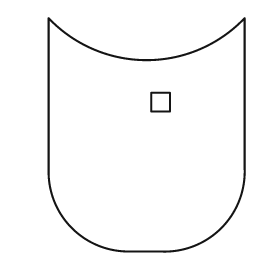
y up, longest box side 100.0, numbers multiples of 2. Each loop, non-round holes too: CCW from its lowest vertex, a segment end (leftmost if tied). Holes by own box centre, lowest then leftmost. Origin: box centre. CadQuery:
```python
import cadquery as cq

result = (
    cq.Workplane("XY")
    .moveTo(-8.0, -50.0)
    .lineTo(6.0, -50.0)
    .threePointArc((32.0, -40.0), (42.0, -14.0))
    .lineTo(42.0, 50.0)
    .threePointArc((0.0, 32.0), (-42.0, 50.0))
    .lineTo(-42.0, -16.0)
    .threePointArc((-32.0, -40.0), (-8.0, -50.0))
    .close()
    .moveTo(2.0, 10.0)
    .lineTo(10.0, 10.0)
    .lineTo(10.0, 18.0)
    .lineTo(2.0, 18.0)
    .close()
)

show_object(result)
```